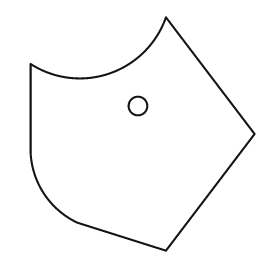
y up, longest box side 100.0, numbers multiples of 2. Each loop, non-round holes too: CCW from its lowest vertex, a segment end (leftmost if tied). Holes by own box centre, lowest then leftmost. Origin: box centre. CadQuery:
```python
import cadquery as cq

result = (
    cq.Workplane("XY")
    .moveTo(10.0, -50.0)
    .lineTo(48.0, 0.0)
    .lineTo(10.0, 50.0)
    .threePointArc((-14.0, 26.0), (-48.0, 30.0))
    .lineTo(-48.0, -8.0)
    .threePointArc((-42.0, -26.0), (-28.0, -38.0))
    .close()
    .moveTo(-2.0, 12.0)
    .circle(4.0)
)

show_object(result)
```